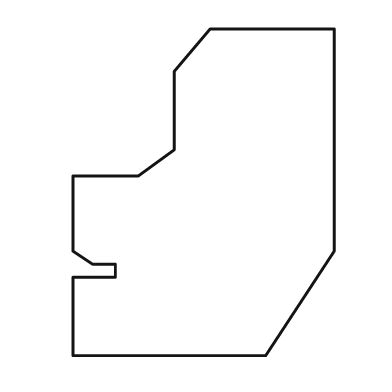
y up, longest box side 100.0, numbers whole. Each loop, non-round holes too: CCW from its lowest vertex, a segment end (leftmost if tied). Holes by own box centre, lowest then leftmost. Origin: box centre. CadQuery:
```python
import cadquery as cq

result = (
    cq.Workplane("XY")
    .moveTo(-40.0, -50.0)
    .lineTo(19.0, -50.0)
    .lineTo(40.0, -18.0)
    .lineTo(40.0, 50.0)
    .lineTo(2.0, 50.0)
    .lineTo(-9.0, 37.0)
    .lineTo(-9.0, 13.0)
    .lineTo(-20.0, 5.0)
    .lineTo(-40.0, 5.0)
    .lineTo(-40.0, -18.0)
    .lineTo(-34.0, -22.0)
    .lineTo(-27.0, -22.0)
    .lineTo(-27.0, -26.0)
    .lineTo(-40.0, -26.0)
    .close()
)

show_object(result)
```